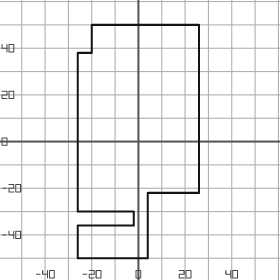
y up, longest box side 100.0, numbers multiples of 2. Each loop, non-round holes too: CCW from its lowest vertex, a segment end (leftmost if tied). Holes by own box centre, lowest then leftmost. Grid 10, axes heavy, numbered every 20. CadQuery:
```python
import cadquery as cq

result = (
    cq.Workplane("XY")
    .moveTo(-26.0, -50.0)
    .lineTo(4.0, -50.0)
    .lineTo(4.0, -22.0)
    .lineTo(26.0, -22.0)
    .lineTo(26.0, 50.0)
    .lineTo(-20.0, 50.0)
    .lineTo(-20.0, 38.0)
    .lineTo(-26.0, 38.0)
    .lineTo(-26.0, -30.0)
    .lineTo(-2.0, -30.0)
    .lineTo(-2.0, -36.0)
    .lineTo(-26.0, -36.0)
    .close()
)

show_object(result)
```